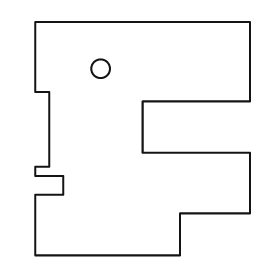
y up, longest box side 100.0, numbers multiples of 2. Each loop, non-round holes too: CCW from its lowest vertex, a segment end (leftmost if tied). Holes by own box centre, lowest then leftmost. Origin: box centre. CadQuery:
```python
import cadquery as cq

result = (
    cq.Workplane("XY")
    .moveTo(-46.0, -50.0)
    .lineTo(16.0, -50.0)
    .lineTo(16.0, -32.0)
    .lineTo(46.0, -32.0)
    .lineTo(46.0, -6.0)
    .lineTo(0.0, -6.0)
    .lineTo(0.0, 16.0)
    .lineTo(46.0, 16.0)
    .lineTo(46.0, 50.0)
    .lineTo(-46.0, 50.0)
    .lineTo(-46.0, 20.0)
    .lineTo(-40.0, 20.0)
    .lineTo(-40.0, -12.0)
    .lineTo(-46.0, -12.0)
    .lineTo(-46.0, -16.0)
    .lineTo(-34.0, -16.0)
    .lineTo(-34.0, -24.0)
    .lineTo(-46.0, -24.0)
    .close()
    .moveTo(-18.0, 30.0)
    .circle(4.0)
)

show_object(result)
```